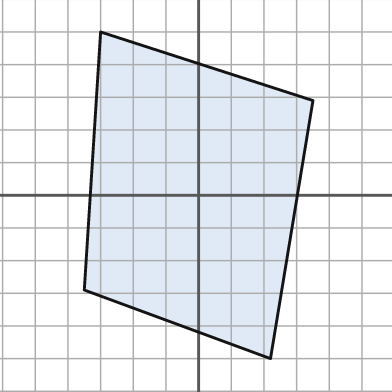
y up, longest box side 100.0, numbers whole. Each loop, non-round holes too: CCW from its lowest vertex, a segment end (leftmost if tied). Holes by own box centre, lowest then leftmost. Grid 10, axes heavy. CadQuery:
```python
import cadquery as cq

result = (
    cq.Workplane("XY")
    .moveTo(22.0, -50.0)
    .lineTo(35.0, 29.0)
    .lineTo(-30.0, 50.0)
    .lineTo(-35.0, -29.0)
    .close()
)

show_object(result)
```